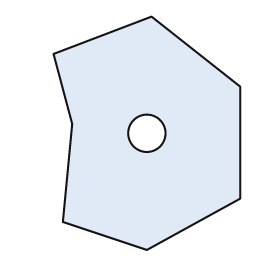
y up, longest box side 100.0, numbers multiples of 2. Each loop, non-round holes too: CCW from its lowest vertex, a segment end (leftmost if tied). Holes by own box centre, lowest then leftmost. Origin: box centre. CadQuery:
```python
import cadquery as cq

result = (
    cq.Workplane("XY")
    .moveTo(0.0, -50.0)
    .lineTo(40.0, -28.0)
    .lineTo(40.0, 20.0)
    .lineTo(2.0, 50.0)
    .lineTo(-40.0, 34.0)
    .lineTo(-32.0, 4.0)
    .lineTo(-36.0, -38.0)
    .close()
    .moveTo(0.0, 0.0)
    .circle(8.0)
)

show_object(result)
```